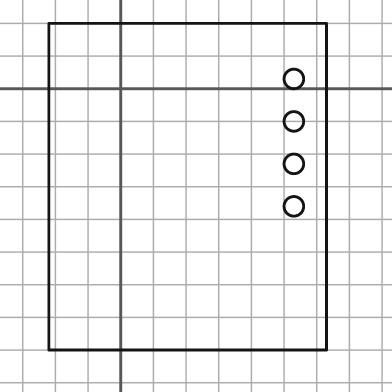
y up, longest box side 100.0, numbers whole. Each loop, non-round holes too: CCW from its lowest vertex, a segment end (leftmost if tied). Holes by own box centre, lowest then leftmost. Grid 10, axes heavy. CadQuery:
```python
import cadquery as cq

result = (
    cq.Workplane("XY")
    .moveTo(-22.0, -80.0)
    .lineTo(63.0, -80.0)
    .lineTo(63.0, 20.0)
    .lineTo(-22.0, 20.0)
    .close()
    .moveTo(53.0, -36.0)
    .circle(3.0)
    .moveTo(53.0, -23.0)
    .circle(3.0)
    .moveTo(53.0, -10.0)
    .circle(3.0)
    .moveTo(53.0, 3.0)
    .circle(3.0)
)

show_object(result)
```